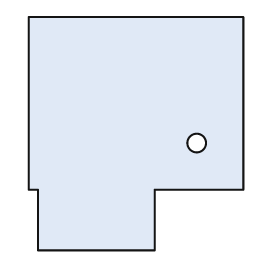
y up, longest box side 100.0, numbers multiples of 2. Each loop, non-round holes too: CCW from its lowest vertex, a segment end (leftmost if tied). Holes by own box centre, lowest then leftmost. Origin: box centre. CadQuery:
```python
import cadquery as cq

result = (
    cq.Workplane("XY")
    .moveTo(-42.0, -50.0)
    .lineTo(8.0, -50.0)
    .lineTo(8.0, -24.0)
    .lineTo(46.0, -24.0)
    .lineTo(46.0, 50.0)
    .lineTo(-46.0, 50.0)
    .lineTo(-46.0, -24.0)
    .lineTo(-42.0, -24.0)
    .close()
    .moveTo(26.0, -4.0)
    .circle(4.0)
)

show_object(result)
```